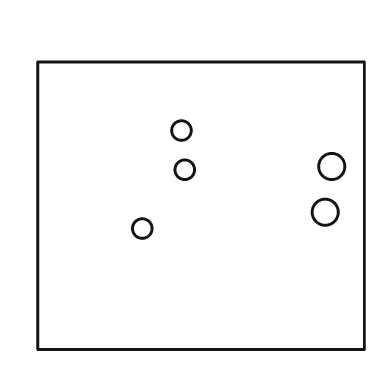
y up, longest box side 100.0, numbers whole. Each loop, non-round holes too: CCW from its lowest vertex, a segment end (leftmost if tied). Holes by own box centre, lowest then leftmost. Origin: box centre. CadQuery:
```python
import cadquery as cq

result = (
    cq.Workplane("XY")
    .moveTo(-50.0, -44.0)
    .lineTo(50.0, -44.0)
    .lineTo(50.0, 44.0)
    .lineTo(-50.0, 44.0)
    .close()
    .moveTo(-18.0, -7.0)
    .circle(3.0)
    .moveTo(38.0, -2.0)
    .circle(4.0)
    .moveTo(-5.0, 11.0)
    .circle(3.0)
    .moveTo(40.0, 12.0)
    .circle(4.0)
    .moveTo(-6.0, 23.0)
    .circle(3.0)
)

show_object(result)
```